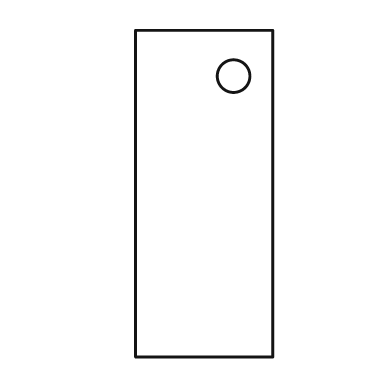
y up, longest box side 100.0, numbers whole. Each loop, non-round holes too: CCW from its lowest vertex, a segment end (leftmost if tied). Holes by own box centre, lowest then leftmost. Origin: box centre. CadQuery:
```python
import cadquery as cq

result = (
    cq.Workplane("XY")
    .moveTo(-21.0, -50.0)
    .lineTo(21.0, -50.0)
    .lineTo(21.0, 50.0)
    .lineTo(-21.0, 50.0)
    .close()
    .moveTo(9.0, 36.0)
    .circle(5.0)
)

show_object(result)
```